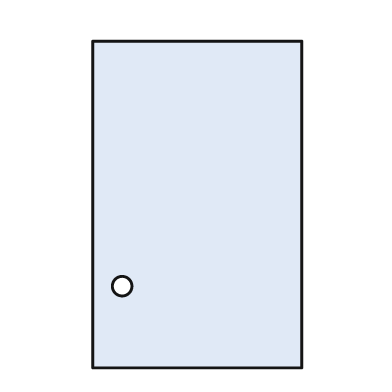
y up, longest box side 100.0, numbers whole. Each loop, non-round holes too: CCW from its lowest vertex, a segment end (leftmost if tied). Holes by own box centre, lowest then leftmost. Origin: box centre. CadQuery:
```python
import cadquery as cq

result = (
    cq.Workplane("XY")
    .moveTo(-32.0, -50.0)
    .lineTo(32.0, -50.0)
    .lineTo(32.0, 50.0)
    .lineTo(-32.0, 50.0)
    .close()
    .moveTo(-23.0, -25.0)
    .circle(3.0)
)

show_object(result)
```